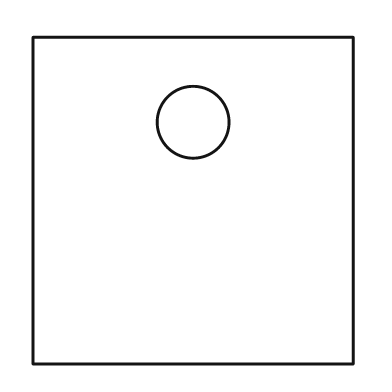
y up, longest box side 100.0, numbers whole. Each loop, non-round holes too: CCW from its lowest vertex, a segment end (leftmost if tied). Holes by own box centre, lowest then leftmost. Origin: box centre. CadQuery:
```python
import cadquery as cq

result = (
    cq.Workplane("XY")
    .moveTo(-49.0, -50.0)
    .lineTo(49.0, -50.0)
    .lineTo(49.0, 50.0)
    .lineTo(-49.0, 50.0)
    .close()
    .moveTo(0.0, 24.0)
    .circle(11.0)
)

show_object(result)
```